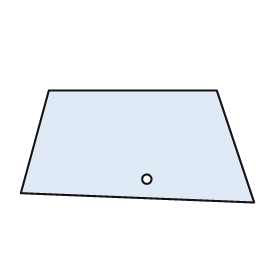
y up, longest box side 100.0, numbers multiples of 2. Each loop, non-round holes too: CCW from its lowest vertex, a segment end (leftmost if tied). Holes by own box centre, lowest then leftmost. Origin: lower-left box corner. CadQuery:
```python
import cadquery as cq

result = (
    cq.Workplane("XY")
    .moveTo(100.0, 0.0)
    .lineTo(84.0, 48.0)
    .lineTo(12.0, 48.0)
    .lineTo(0.0, 4.0)
    .close()
    .moveTo(54.0, 10.0)
    .circle(2.0)
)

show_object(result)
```